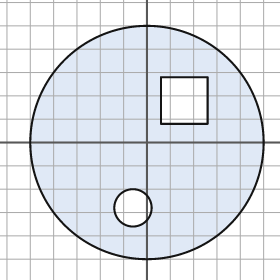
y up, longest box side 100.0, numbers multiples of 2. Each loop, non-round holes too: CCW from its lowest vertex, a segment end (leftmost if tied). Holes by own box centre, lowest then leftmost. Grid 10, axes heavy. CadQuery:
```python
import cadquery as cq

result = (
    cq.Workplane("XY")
    .moveTo(0.0, 0.0)
    .circle(50.0)
    .moveTo(-6.0, -28.0)
    .circle(8.0)
    .moveTo(6.0, 8.0)
    .lineTo(26.0, 8.0)
    .lineTo(26.0, 28.0)
    .lineTo(6.0, 28.0)
    .close()
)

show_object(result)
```